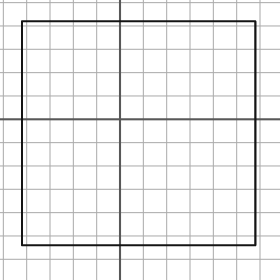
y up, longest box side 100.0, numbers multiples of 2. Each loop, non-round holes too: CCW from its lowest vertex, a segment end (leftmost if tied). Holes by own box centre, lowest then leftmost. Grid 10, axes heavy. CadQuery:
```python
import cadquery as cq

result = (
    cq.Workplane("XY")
    .moveTo(-42.0, -54.0)
    .lineTo(58.0, -54.0)
    .lineTo(58.0, 42.0)
    .lineTo(-42.0, 42.0)
    .close()
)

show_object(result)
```